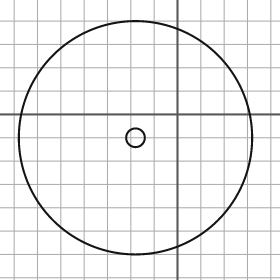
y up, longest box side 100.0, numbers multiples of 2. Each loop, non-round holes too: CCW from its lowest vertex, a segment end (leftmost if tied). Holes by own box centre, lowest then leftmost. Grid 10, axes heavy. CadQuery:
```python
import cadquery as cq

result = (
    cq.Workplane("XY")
    .moveTo(-18.0, -10.0)
    .circle(50.0)
    .moveTo(-18.0, -10.0)
    .circle(4.0)
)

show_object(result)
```